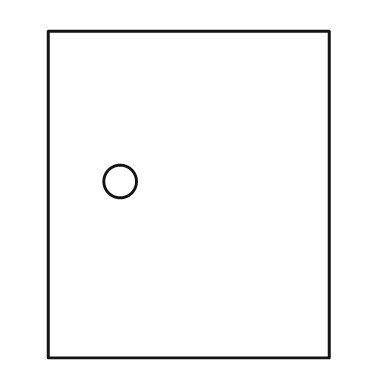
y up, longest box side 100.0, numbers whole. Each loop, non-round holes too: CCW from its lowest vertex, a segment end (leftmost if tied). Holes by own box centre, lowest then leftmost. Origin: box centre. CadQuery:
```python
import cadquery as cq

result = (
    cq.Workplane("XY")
    .moveTo(-43.0, -50.0)
    .lineTo(43.0, -50.0)
    .lineTo(43.0, 50.0)
    .lineTo(-43.0, 50.0)
    .close()
    .moveTo(-21.0, 4.0)
    .circle(5.0)
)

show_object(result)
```